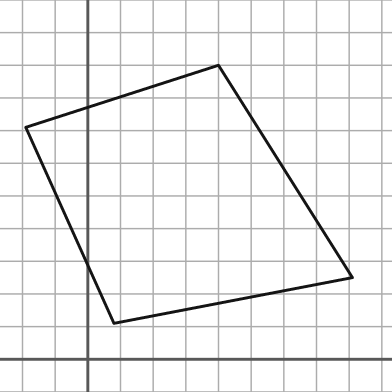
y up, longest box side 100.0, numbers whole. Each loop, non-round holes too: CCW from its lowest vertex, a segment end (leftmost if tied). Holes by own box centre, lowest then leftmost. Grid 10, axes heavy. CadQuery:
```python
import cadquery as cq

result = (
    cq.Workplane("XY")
    .moveTo(8.0, 11.0)
    .lineTo(81.0, 25.0)
    .lineTo(40.0, 90.0)
    .lineTo(-19.0, 71.0)
    .close()
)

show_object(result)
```